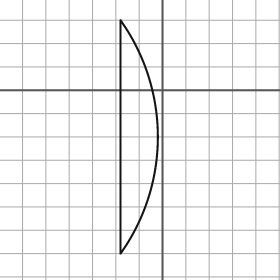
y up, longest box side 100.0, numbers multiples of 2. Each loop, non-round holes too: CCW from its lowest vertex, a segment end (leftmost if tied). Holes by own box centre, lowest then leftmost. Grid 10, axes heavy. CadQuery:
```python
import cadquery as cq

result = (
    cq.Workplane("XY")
    .moveTo(-18.0, -70.0)
    .threePointArc((-2.0, -20.0), (-18.0, 30.0))
    .close()
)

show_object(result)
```